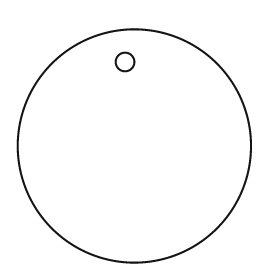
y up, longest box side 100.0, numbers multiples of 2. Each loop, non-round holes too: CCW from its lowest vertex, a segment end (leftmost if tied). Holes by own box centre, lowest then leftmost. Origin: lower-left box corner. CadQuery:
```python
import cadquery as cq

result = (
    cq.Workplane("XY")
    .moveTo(50.0, 50.0)
    .circle(50.0)
    .moveTo(46.0, 86.0)
    .circle(4.0)
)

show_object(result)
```